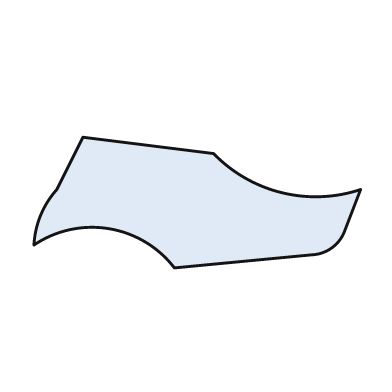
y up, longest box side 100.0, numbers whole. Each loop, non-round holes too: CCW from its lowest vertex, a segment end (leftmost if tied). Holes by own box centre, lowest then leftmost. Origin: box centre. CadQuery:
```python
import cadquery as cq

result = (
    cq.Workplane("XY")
    .moveTo(-7.0, -20.0)
    .lineTo(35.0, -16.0)
    .threePointArc((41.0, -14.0), (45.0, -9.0))
    .lineTo(50.0, 4.0)
    .threePointArc((26.0, 3.0), (5.0, 15.0))
    .lineTo(-35.0, 20.0)
    .lineTo(-43.0, 4.0)
    .threePointArc((-48.0, -4.0), (-50.0, -13.0))
    .threePointArc((-27.0, -8.0), (-7.0, -20.0))
    .close()
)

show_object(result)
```